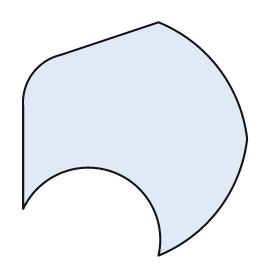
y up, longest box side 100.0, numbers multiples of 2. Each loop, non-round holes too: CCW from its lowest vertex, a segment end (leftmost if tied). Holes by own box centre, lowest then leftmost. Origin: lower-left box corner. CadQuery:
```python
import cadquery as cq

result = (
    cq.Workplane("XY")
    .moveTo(58.0, 0.0)
    .threePointArc((84.0, 20.0), (96.0, 50.0))
    .threePointArc((84.0, 80.0), (58.0, 100.0))
    .lineTo(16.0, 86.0)
    .threePointArc((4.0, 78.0), (0.0, 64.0))
    .lineTo(0.0, 20.0)
    .threePointArc((38.0, 36.0), (58.0, 0.0))
    .close()
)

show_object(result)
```